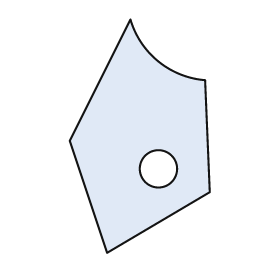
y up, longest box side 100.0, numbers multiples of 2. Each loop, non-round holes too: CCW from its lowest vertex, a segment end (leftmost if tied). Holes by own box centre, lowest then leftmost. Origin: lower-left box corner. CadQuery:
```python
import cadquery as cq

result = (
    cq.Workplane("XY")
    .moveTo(16.0, 0.0)
    .lineTo(60.0, 26.0)
    .lineTo(58.0, 74.0)
    .threePointArc((38.0, 82.0), (26.0, 100.0))
    .lineTo(0.0, 48.0)
    .close()
    .moveTo(38.0, 36.0)
    .circle(8.0)
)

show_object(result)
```